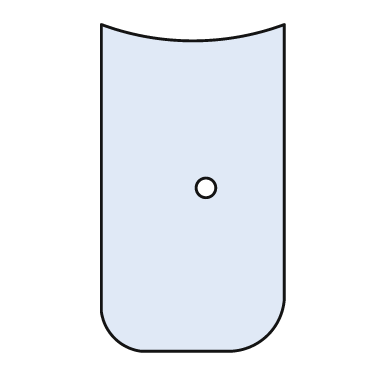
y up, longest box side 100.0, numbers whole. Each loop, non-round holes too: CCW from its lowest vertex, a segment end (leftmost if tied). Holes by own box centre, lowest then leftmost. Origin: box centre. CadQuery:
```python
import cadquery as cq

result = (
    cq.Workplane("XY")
    .moveTo(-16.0, -50.0)
    .lineTo(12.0, -50.0)
    .threePointArc((23.0, -45.0), (28.0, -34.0))
    .lineTo(28.0, 50.0)
    .threePointArc((0.0, 45.0), (-28.0, 50.0))
    .lineTo(-28.0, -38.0)
    .threePointArc((-24.0, -46.0), (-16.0, -50.0))
    .close()
    .moveTo(4.0, 0.0)
    .circle(3.0)
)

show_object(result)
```